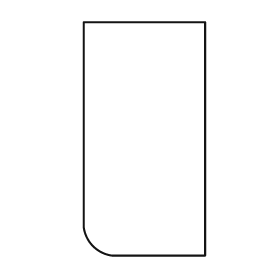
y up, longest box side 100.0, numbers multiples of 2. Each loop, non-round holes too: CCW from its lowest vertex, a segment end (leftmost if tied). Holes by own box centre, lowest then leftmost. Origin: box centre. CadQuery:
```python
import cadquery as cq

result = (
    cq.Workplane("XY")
    .moveTo(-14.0, -50.0)
    .lineTo(26.0, -50.0)
    .lineTo(26.0, 50.0)
    .lineTo(-26.0, 50.0)
    .lineTo(-26.0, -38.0)
    .threePointArc((-22.0, -46.0), (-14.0, -50.0))
    .close()
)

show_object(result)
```